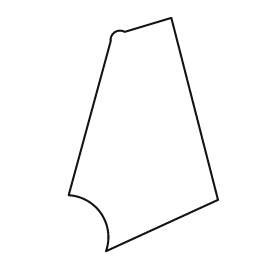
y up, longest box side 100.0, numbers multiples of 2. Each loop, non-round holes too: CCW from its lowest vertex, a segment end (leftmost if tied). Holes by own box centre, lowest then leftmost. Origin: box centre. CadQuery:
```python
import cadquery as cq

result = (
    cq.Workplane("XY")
    .moveTo(-16.0, -50.0)
    .lineTo(32.0, -28.0)
    .lineTo(12.0, 50.0)
    .lineTo(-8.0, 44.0)
    .threePointArc((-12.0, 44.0), (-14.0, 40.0))
    .lineTo(-32.0, -26.0)
    .threePointArc((-18.0, -34.0), (-16.0, -50.0))
    .close()
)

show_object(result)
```